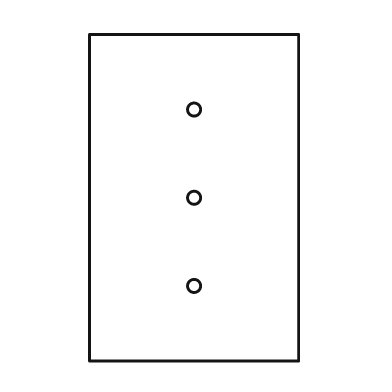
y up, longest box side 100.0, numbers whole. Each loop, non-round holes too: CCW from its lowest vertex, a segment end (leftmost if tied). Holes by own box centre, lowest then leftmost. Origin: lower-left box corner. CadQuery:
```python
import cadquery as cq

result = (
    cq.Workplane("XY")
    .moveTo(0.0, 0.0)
    .lineTo(64.0, 0.0)
    .lineTo(64.0, 100.0)
    .lineTo(0.0, 100.0)
    .close()
    .moveTo(32.0, 23.0)
    .circle(2.0)
    .moveTo(32.0, 50.0)
    .circle(2.0)
    .moveTo(32.0, 77.0)
    .circle(2.0)
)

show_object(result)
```